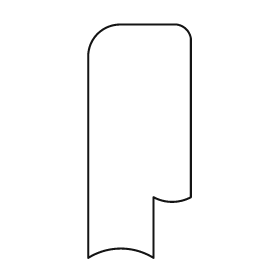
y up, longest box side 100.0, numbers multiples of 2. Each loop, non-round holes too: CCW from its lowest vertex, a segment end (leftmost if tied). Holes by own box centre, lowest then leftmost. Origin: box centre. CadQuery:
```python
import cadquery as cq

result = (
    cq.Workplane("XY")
    .moveTo(-22.0, -50.0)
    .threePointArc((-8.0, -46.0), (6.0, -50.0))
    .lineTo(6.0, -24.0)
    .threePointArc((14.0, -26.0), (22.0, -24.0))
    .lineTo(22.0, 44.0)
    .threePointArc((20.0, 48.0), (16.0, 50.0))
    .lineTo(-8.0, 50.0)
    .threePointArc((-18.0, 46.0), (-22.0, 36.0))
    .close()
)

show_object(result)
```